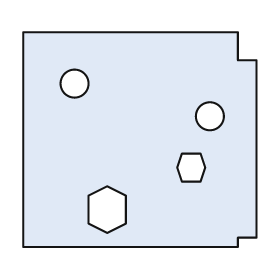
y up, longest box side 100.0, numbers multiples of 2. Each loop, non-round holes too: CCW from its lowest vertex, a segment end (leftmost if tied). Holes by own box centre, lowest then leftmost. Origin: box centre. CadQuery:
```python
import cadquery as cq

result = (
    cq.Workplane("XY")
    .moveTo(-50.0, -46.0)
    .lineTo(42.0, -46.0)
    .lineTo(42.0, -42.0)
    .lineTo(50.0, -42.0)
    .lineTo(50.0, 34.0)
    .lineTo(42.0, 34.0)
    .lineTo(42.0, 46.0)
    .lineTo(-50.0, 46.0)
    .close()
    .moveTo(-14.0, -40.0)
    .lineTo(-6.0, -36.0)
    .lineTo(-6.0, -24.0)
    .lineTo(-14.0, -20.0)
    .lineTo(-22.0, -24.0)
    .lineTo(-22.0, -36.0)
    .close()
    .moveTo(18.0, -18.0)
    .lineTo(26.0, -18.0)
    .lineTo(28.0, -12.0)
    .lineTo(26.0, -6.0)
    .lineTo(18.0, -6.0)
    .lineTo(16.0, -12.0)
    .close()
    .moveTo(30.0, 10.0)
    .circle(6.0)
    .moveTo(-28.0, 24.0)
    .circle(6.0)
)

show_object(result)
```